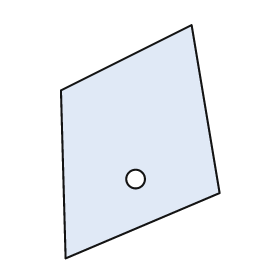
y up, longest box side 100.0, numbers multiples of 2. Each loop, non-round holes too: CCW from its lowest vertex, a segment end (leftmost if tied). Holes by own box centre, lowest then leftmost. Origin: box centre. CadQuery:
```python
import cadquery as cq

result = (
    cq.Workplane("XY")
    .moveTo(-32.0, -50.0)
    .lineTo(34.0, -22.0)
    .lineTo(22.0, 50.0)
    .lineTo(-34.0, 22.0)
    .close()
    .moveTo(-2.0, -16.0)
    .circle(4.0)
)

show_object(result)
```